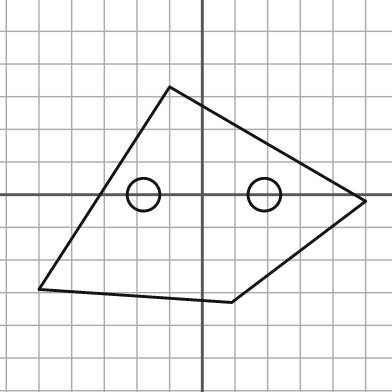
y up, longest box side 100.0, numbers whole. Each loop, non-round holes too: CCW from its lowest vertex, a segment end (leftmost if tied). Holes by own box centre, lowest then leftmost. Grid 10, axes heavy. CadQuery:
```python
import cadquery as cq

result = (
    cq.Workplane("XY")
    .moveTo(9.0, -33.0)
    .lineTo(50.0, -2.0)
    .lineTo(-10.0, 33.0)
    .lineTo(-50.0, -29.0)
    .close()
    .moveTo(-18.0, 0.0)
    .circle(5.0)
    .moveTo(19.0, 0.0)
    .circle(5.0)
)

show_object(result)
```